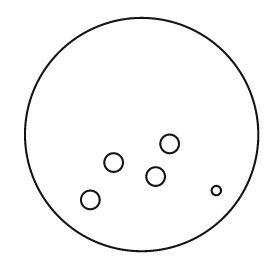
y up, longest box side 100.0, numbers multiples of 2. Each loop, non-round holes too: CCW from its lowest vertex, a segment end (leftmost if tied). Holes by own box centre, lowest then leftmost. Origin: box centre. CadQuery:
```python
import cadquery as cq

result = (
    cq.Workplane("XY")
    .moveTo(0.0, 0.0)
    .circle(50.0)
    .moveTo(-22.0, -28.0)
    .circle(4.0)
    .moveTo(32.0, -24.0)
    .circle(2.0)
    .moveTo(6.0, -18.0)
    .circle(4.0)
    .moveTo(-12.0, -12.0)
    .circle(4.0)
    .moveTo(12.0, -4.0)
    .circle(4.0)
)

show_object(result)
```